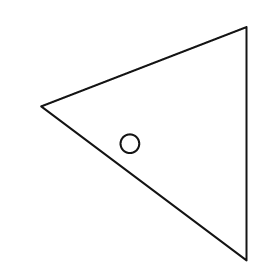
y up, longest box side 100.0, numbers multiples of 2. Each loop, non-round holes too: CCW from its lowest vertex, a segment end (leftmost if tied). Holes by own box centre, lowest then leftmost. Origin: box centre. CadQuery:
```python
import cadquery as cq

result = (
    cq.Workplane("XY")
    .moveTo(44.0, -50.0)
    .lineTo(44.0, 50.0)
    .lineTo(-44.0, 16.0)
    .close()
    .moveTo(-6.0, 0.0)
    .circle(4.0)
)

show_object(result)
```